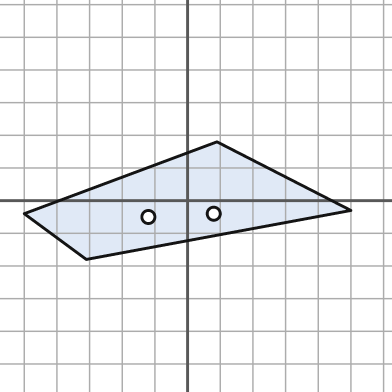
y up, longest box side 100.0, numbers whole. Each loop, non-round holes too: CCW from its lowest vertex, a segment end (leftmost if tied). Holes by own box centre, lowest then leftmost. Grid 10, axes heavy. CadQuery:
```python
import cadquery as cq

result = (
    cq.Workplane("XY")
    .moveTo(-31.0, -18.0)
    .lineTo(50.0, -3.0)
    .lineTo(9.0, 18.0)
    .lineTo(-50.0, -4.0)
    .close()
    .moveTo(-12.0, -5.0)
    .circle(2.0)
    .moveTo(8.0, -4.0)
    .circle(2.0)
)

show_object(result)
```